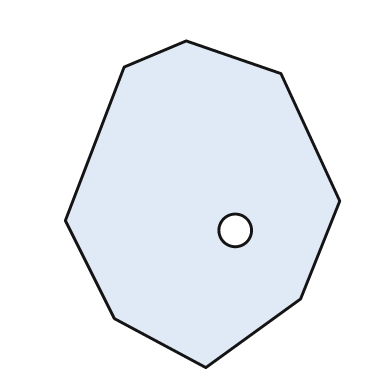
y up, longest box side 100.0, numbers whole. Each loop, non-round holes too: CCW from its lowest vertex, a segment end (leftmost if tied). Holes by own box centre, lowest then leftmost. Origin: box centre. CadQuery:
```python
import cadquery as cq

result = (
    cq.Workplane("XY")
    .moveTo(1.0, -50.0)
    .lineTo(30.0, -29.0)
    .lineTo(42.0, 1.0)
    .lineTo(24.0, 40.0)
    .lineTo(-5.0, 50.0)
    .lineTo(-24.0, 42.0)
    .lineTo(-42.0, -5.0)
    .lineTo(-27.0, -35.0)
    .close()
    .moveTo(10.0, -8.0)
    .circle(5.0)
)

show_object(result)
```